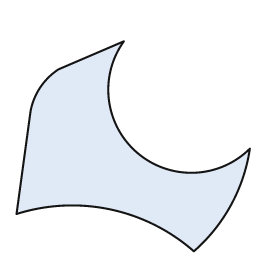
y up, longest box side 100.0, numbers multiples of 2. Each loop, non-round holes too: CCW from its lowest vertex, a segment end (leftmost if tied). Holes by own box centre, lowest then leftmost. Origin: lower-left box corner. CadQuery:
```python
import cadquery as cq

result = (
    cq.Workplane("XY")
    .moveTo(76.0, 0.0)
    .threePointArc((92.0, 20.0), (100.0, 44.0))
    .threePointArc((52.0, 42.0), (46.0, 90.0))
    .lineTo(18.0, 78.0)
    .threePointArc((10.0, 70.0), (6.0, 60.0))
    .lineTo(0.0, 16.0)
    .threePointArc((40.0, 18.0), (76.0, 0.0))
    .close()
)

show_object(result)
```